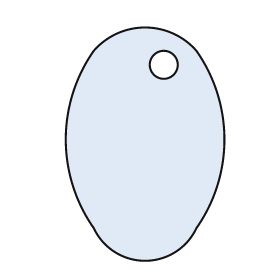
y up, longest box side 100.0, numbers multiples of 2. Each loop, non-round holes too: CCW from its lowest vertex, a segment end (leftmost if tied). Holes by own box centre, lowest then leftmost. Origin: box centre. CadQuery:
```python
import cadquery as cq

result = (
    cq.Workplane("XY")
    .moveTo(-22.0, -36.0)
    .threePointArc((0.0, -50.0), (22.0, -36.0))
    .threePointArc((34.0, 2.0), (22.0, 40.0))
    .threePointArc((0.0, 50.0), (-22.0, 40.0))
    .threePointArc((-34.0, 2.0), (-22.0, -36.0))
    .close()
    .moveTo(8.0, 34.0)
    .circle(6.0)
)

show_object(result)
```